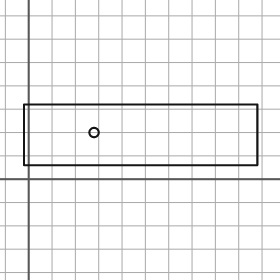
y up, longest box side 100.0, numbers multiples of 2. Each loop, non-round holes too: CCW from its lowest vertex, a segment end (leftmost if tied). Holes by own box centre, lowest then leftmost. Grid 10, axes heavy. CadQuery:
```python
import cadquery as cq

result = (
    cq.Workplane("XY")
    .moveTo(-2.0, 6.0)
    .lineTo(98.0, 6.0)
    .lineTo(98.0, 32.0)
    .lineTo(-2.0, 32.0)
    .close()
    .moveTo(28.0, 20.0)
    .circle(2.0)
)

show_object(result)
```